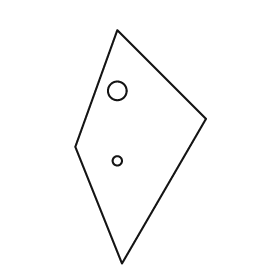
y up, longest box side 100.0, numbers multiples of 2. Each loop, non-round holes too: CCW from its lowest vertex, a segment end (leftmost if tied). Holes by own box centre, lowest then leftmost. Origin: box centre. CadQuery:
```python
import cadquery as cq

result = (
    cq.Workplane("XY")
    .moveTo(-8.0, -50.0)
    .lineTo(28.0, 12.0)
    .lineTo(-10.0, 50.0)
    .lineTo(-28.0, 0.0)
    .close()
    .moveTo(-10.0, -6.0)
    .circle(2.0)
    .moveTo(-10.0, 24.0)
    .circle(4.0)
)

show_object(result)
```